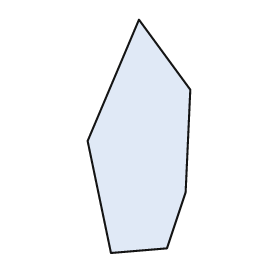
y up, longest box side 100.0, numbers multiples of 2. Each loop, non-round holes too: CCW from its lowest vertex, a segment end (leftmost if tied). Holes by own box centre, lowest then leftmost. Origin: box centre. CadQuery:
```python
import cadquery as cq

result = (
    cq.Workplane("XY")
    .moveTo(-12.0, -50.0)
    .lineTo(12.0, -48.0)
    .lineTo(20.0, -24.0)
    .lineTo(22.0, 20.0)
    .lineTo(0.0, 50.0)
    .lineTo(-22.0, -2.0)
    .close()
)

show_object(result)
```